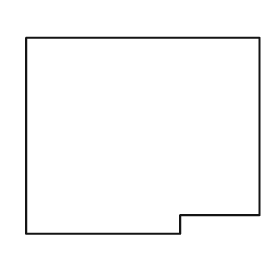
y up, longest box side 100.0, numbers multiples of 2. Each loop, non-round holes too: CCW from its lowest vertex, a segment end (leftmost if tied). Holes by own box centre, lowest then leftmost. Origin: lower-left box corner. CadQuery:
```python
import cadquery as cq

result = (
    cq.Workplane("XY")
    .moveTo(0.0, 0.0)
    .lineTo(66.0, 0.0)
    .lineTo(66.0, 8.0)
    .lineTo(100.0, 8.0)
    .lineTo(100.0, 84.0)
    .lineTo(0.0, 84.0)
    .close()
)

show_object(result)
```